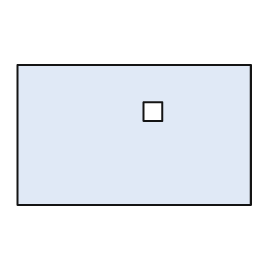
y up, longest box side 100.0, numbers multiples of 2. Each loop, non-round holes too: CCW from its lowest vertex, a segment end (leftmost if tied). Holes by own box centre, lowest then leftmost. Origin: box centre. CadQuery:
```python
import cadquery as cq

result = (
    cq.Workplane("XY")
    .moveTo(-50.0, -30.0)
    .lineTo(50.0, -30.0)
    .lineTo(50.0, 30.0)
    .lineTo(-50.0, 30.0)
    .close()
    .moveTo(4.0, 6.0)
    .lineTo(12.0, 6.0)
    .lineTo(12.0, 14.0)
    .lineTo(4.0, 14.0)
    .close()
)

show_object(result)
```